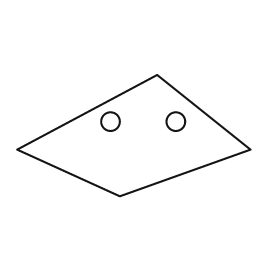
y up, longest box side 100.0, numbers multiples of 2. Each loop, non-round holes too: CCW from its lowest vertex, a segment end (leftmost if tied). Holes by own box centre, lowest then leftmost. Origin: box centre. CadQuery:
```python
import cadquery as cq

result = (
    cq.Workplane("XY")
    .moveTo(-6.0, -26.0)
    .lineTo(50.0, -6.0)
    .lineTo(10.0, 26.0)
    .lineTo(-50.0, -6.0)
    .close()
    .moveTo(-10.0, 6.0)
    .circle(4.0)
    .moveTo(18.0, 6.0)
    .circle(4.0)
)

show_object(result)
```